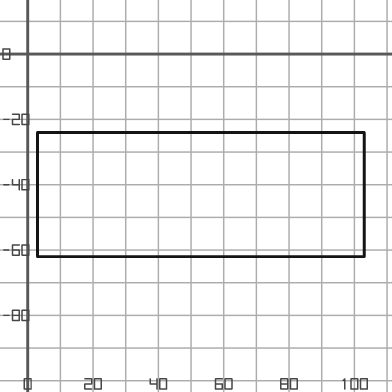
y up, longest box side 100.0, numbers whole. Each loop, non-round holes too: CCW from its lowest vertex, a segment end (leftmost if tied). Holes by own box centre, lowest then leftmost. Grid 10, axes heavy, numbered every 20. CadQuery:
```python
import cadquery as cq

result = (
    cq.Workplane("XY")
    .moveTo(3.0, -62.0)
    .lineTo(103.0, -62.0)
    .lineTo(103.0, -24.0)
    .lineTo(3.0, -24.0)
    .close()
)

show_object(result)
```